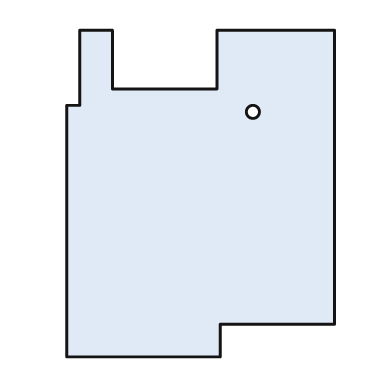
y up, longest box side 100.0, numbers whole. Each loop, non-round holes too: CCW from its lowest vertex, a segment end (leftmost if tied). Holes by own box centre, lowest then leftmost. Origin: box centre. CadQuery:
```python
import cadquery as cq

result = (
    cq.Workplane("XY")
    .moveTo(-41.0, -50.0)
    .lineTo(6.0, -50.0)
    .lineTo(6.0, -40.0)
    .lineTo(41.0, -40.0)
    .lineTo(41.0, 50.0)
    .lineTo(5.0, 50.0)
    .lineTo(5.0, 32.0)
    .lineTo(-27.0, 32.0)
    .lineTo(-27.0, 50.0)
    .lineTo(-37.0, 50.0)
    .lineTo(-37.0, 27.0)
    .lineTo(-41.0, 27.0)
    .close()
    .moveTo(16.0, 25.0)
    .circle(2.0)
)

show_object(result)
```